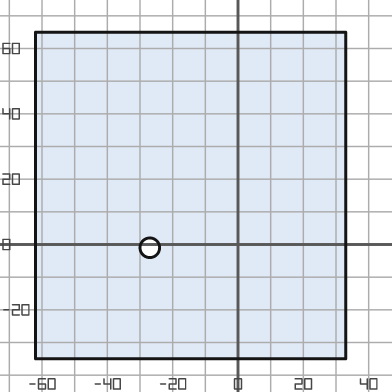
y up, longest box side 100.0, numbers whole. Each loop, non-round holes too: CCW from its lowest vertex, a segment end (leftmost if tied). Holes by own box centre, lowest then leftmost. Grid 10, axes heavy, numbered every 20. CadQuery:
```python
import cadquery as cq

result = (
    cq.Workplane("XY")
    .moveTo(-62.0, -35.0)
    .lineTo(33.0, -35.0)
    .lineTo(33.0, 65.0)
    .lineTo(-62.0, 65.0)
    .close()
    .moveTo(-27.0, -1.0)
    .circle(3.0)
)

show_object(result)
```